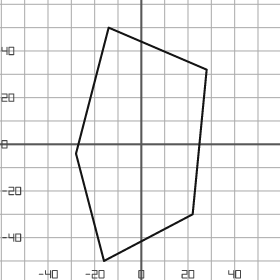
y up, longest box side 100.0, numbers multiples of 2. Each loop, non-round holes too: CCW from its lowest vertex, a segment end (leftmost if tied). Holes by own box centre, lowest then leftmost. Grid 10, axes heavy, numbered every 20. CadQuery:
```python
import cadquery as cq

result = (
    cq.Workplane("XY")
    .moveTo(-16.0, -50.0)
    .lineTo(22.0, -30.0)
    .lineTo(28.0, 32.0)
    .lineTo(-14.0, 50.0)
    .lineTo(-28.0, -4.0)
    .close()
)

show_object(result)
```